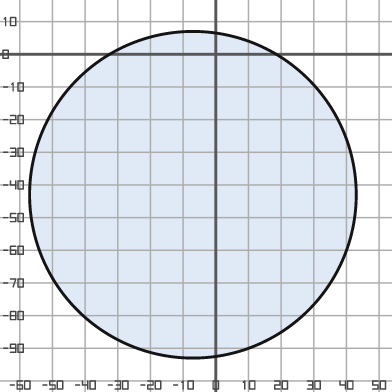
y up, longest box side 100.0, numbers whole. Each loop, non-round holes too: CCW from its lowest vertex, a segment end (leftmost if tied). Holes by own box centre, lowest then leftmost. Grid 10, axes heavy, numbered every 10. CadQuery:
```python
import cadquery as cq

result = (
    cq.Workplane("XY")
    .moveTo(-7.0, -43.0)
    .circle(50.0)
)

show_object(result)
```